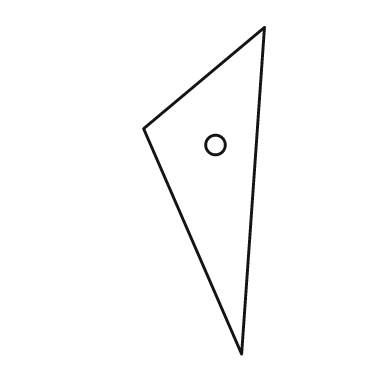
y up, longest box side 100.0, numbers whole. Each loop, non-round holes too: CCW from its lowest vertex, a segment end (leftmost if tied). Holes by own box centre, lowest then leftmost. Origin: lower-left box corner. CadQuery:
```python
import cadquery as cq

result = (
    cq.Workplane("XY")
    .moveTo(30.0, 0.0)
    .lineTo(37.0, 100.0)
    .lineTo(0.0, 69.0)
    .close()
    .moveTo(22.0, 64.0)
    .circle(3.0)
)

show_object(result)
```